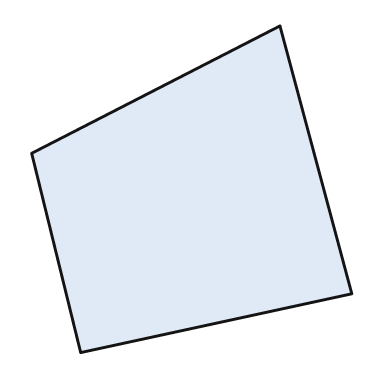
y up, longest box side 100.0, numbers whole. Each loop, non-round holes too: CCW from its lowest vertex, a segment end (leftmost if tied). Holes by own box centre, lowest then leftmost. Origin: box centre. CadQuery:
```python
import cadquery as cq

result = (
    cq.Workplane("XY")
    .moveTo(-34.0, -50.0)
    .lineTo(49.0, -32.0)
    .lineTo(27.0, 50.0)
    .lineTo(-49.0, 11.0)
    .close()
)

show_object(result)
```